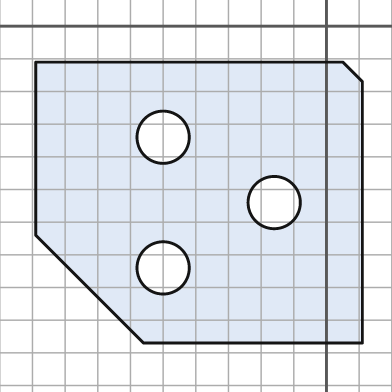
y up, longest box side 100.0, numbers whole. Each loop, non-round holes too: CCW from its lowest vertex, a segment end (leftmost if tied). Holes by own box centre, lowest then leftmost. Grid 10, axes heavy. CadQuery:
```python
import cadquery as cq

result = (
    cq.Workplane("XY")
    .moveTo(-56.0, -97.0)
    .lineTo(11.0, -97.0)
    .lineTo(11.0, -17.0)
    .lineTo(5.0, -11.0)
    .lineTo(-89.0, -11.0)
    .lineTo(-89.0, -64.0)
    .close()
    .moveTo(-50.0, -74.0)
    .circle(8.0)
    .moveTo(-16.0, -54.0)
    .circle(8.0)
    .moveTo(-50.0, -34.0)
    .circle(8.0)
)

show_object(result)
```